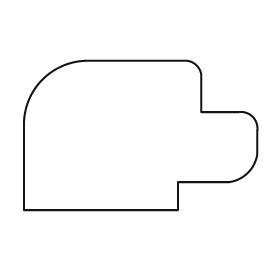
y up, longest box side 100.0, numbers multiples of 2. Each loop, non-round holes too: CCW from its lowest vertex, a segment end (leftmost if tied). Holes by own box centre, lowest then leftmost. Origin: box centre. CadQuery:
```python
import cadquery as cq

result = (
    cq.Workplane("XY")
    .moveTo(-50.0, -32.0)
    .lineTo(16.0, -32.0)
    .lineTo(16.0, -20.0)
    .lineTo(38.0, -20.0)
    .threePointArc((46.0, -16.0), (50.0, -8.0))
    .lineTo(50.0, 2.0)
    .threePointArc((48.0, 8.0), (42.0, 10.0))
    .lineTo(26.0, 10.0)
    .lineTo(26.0, 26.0)
    .threePointArc((24.0, 30.0), (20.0, 32.0))
    .lineTo(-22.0, 32.0)
    .threePointArc((-42.0, 24.0), (-50.0, 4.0))
    .close()
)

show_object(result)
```